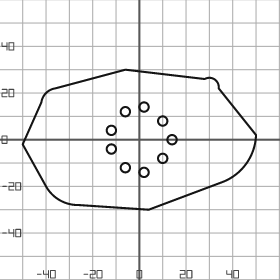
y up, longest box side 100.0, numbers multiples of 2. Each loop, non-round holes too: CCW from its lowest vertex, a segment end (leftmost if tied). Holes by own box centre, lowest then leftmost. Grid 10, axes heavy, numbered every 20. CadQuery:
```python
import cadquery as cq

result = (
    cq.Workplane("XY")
    .moveTo(4.0, -30.0)
    .lineTo(36.0, -18.0)
    .threePointArc((46.0, -10.0), (50.0, 2.0))
    .lineTo(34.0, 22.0)
    .threePointArc((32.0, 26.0), (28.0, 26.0))
    .lineTo(-6.0, 30.0)
    .lineTo(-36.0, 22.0)
    .threePointArc((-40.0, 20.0), (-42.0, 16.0))
    .lineTo(-50.0, -2.0)
    .lineTo(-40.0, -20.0)
    .threePointArc((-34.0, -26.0), (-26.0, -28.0))
    .close()
    .moveTo(2.0, -14.0)
    .circle(2.0)
    .moveTo(-6.0, -12.0)
    .circle(2.0)
    .moveTo(10.0, -8.0)
    .circle(2.0)
    .moveTo(-12.0, -4.0)
    .circle(2.0)
    .moveTo(14.0, 0.0)
    .circle(2.0)
    .moveTo(-12.0, 4.0)
    .circle(2.0)
    .moveTo(10.0, 8.0)
    .circle(2.0)
    .moveTo(-6.0, 12.0)
    .circle(2.0)
    .moveTo(2.0, 14.0)
    .circle(2.0)
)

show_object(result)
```